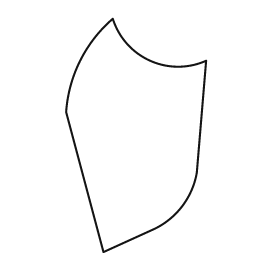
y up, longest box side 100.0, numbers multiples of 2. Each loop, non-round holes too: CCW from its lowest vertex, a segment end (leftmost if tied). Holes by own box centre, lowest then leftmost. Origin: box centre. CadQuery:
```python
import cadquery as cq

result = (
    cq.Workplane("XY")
    .moveTo(-14.0, -50.0)
    .lineTo(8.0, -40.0)
    .threePointArc((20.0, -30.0), (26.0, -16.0))
    .lineTo(30.0, 32.0)
    .threePointArc((6.0, 32.0), (-10.0, 50.0))
    .threePointArc((-24.0, 32.0), (-30.0, 10.0))
    .close()
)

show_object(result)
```